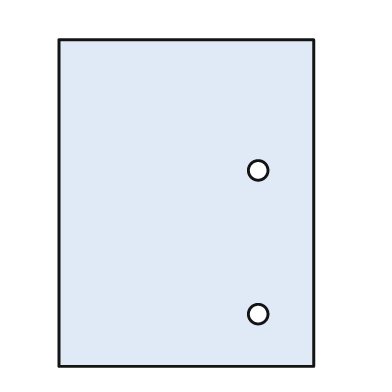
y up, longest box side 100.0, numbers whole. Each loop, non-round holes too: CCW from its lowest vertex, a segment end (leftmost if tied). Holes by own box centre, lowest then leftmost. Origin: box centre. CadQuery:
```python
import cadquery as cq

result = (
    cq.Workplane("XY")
    .moveTo(-39.0, -50.0)
    .lineTo(39.0, -50.0)
    .lineTo(39.0, 50.0)
    .lineTo(-39.0, 50.0)
    .close()
    .moveTo(22.0, -34.0)
    .circle(3.0)
    .moveTo(22.0, 10.0)
    .circle(3.0)
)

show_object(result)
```